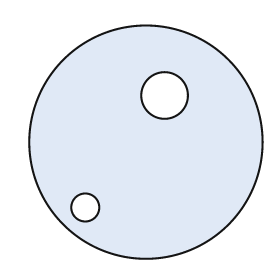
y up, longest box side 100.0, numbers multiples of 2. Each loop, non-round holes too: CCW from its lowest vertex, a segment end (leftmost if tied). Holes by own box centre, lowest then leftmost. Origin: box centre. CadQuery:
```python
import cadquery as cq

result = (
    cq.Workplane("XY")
    .moveTo(0.0, 0.0)
    .circle(50.0)
    .moveTo(-26.0, -28.0)
    .circle(6.0)
    .moveTo(8.0, 20.0)
    .circle(10.0)
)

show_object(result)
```